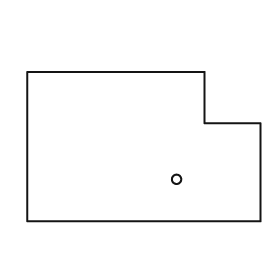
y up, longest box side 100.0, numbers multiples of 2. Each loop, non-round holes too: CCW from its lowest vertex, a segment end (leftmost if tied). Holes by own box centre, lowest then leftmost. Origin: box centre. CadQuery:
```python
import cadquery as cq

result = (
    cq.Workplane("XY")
    .moveTo(-50.0, -32.0)
    .lineTo(50.0, -32.0)
    .lineTo(50.0, 10.0)
    .lineTo(26.0, 10.0)
    .lineTo(26.0, 32.0)
    .lineTo(-50.0, 32.0)
    .close()
    .moveTo(14.0, -14.0)
    .circle(2.0)
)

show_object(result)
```